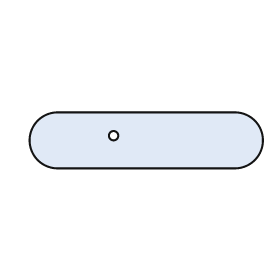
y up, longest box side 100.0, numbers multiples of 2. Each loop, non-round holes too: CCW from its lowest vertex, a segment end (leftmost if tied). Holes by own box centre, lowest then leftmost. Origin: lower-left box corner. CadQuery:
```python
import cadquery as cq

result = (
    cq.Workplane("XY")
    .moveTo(12.0, 0.0)
    .lineTo(88.0, 0.0)
    .threePointArc((100.0, 12.0), (88.0, 24.0))
    .lineTo(12.0, 24.0)
    .threePointArc((0.0, 12.0), (12.0, 0.0))
    .close()
    .moveTo(36.0, 14.0)
    .circle(2.0)
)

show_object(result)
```